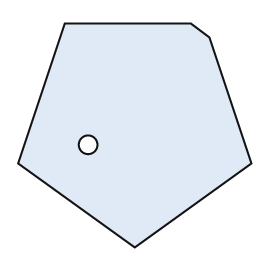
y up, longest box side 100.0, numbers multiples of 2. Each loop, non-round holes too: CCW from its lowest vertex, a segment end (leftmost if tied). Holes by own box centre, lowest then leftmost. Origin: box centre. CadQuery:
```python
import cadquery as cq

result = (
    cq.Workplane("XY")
    .moveTo(0.0, -48.0)
    .lineTo(50.0, -12.0)
    .lineTo(32.0, 42.0)
    .lineTo(24.0, 48.0)
    .lineTo(-30.0, 48.0)
    .lineTo(-50.0, -12.0)
    .close()
    .moveTo(-20.0, -4.0)
    .circle(4.0)
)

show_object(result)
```